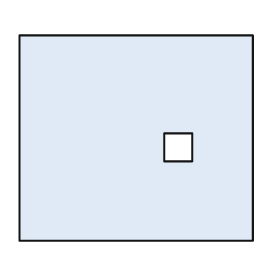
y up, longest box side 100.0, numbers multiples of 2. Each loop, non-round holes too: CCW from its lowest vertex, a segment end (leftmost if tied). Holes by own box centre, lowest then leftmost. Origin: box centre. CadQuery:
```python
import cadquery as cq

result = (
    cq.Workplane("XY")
    .moveTo(-50.0, -44.0)
    .lineTo(50.0, -44.0)
    .lineTo(50.0, 44.0)
    .lineTo(-50.0, 44.0)
    .close()
    .moveTo(12.0, -10.0)
    .lineTo(24.0, -10.0)
    .lineTo(24.0, 2.0)
    .lineTo(12.0, 2.0)
    .close()
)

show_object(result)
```